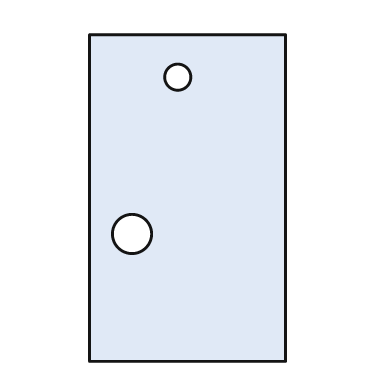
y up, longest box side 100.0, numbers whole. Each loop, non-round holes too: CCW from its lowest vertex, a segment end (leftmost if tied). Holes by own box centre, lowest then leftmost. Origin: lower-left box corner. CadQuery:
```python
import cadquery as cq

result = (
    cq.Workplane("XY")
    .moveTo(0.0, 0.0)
    .lineTo(60.0, 0.0)
    .lineTo(60.0, 100.0)
    .lineTo(0.0, 100.0)
    .close()
    .moveTo(13.0, 39.0)
    .circle(6.0)
    .moveTo(27.0, 87.0)
    .circle(4.0)
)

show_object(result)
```